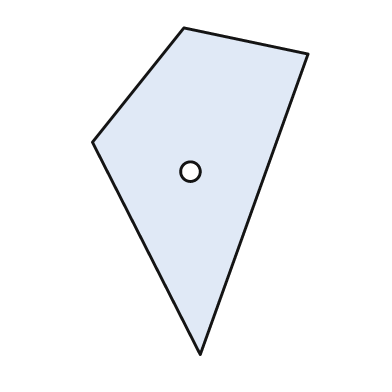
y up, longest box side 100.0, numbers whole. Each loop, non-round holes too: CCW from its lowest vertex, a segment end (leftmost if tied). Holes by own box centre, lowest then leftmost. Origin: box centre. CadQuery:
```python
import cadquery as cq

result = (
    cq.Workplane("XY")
    .moveTo(0.0, -50.0)
    .lineTo(33.0, 42.0)
    .lineTo(-5.0, 50.0)
    .lineTo(-33.0, 15.0)
    .close()
    .moveTo(-3.0, 6.0)
    .circle(3.0)
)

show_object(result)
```